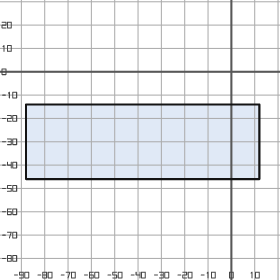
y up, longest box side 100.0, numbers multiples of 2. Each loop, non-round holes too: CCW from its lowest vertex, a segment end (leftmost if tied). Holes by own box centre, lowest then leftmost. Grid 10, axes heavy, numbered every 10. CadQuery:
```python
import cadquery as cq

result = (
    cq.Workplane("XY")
    .moveTo(-88.0, -46.0)
    .lineTo(12.0, -46.0)
    .lineTo(12.0, -14.0)
    .lineTo(-88.0, -14.0)
    .close()
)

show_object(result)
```